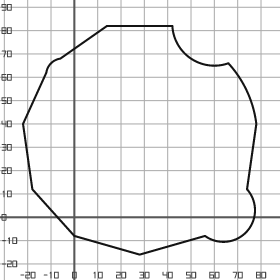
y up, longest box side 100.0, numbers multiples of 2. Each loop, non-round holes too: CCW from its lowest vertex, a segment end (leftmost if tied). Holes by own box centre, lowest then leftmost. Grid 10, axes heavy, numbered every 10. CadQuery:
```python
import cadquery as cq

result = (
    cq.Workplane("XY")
    .moveTo(28.0, -16.0)
    .lineTo(56.0, -8.0)
    .threePointArc((74.0, -6.0), (74.0, 12.0))
    .lineTo(78.0, 40.0)
    .threePointArc((74.0, 54.0), (66.0, 66.0))
    .threePointArc((50.0, 68.0), (42.0, 82.0))
    .lineTo(14.0, 82.0)
    .lineTo(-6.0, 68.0)
    .threePointArc((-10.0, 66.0), (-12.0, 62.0))
    .lineTo(-22.0, 40.0)
    .lineTo(-18.0, 12.0)
    .lineTo(0.0, -8.0)
    .close()
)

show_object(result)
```